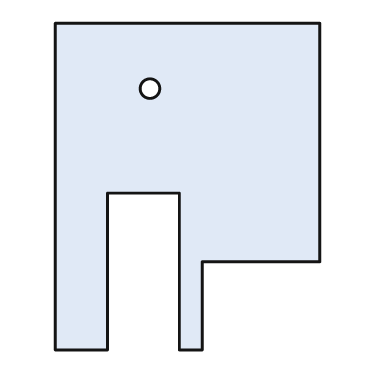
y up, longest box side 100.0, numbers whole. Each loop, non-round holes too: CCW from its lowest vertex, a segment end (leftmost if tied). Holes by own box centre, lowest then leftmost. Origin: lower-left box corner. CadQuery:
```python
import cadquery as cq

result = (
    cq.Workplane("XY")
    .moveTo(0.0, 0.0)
    .lineTo(16.0, 0.0)
    .lineTo(16.0, 48.0)
    .lineTo(38.0, 48.0)
    .lineTo(38.0, 0.0)
    .lineTo(45.0, 0.0)
    .lineTo(45.0, 27.0)
    .lineTo(81.0, 27.0)
    .lineTo(81.0, 100.0)
    .lineTo(0.0, 100.0)
    .close()
    .moveTo(29.0, 80.0)
    .circle(3.0)
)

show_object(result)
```